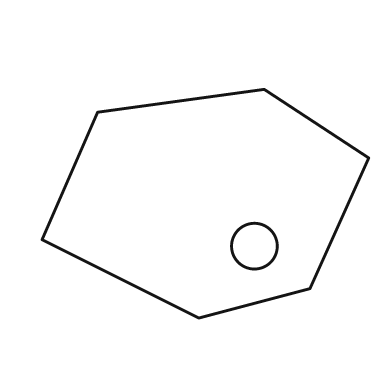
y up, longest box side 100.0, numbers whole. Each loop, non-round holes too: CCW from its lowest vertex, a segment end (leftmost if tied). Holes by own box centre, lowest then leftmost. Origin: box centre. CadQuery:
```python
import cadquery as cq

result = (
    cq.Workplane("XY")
    .moveTo(-2.0, -35.0)
    .lineTo(32.0, -26.0)
    .lineTo(50.0, 14.0)
    .lineTo(18.0, 35.0)
    .lineTo(-33.0, 28.0)
    .lineTo(-50.0, -11.0)
    .close()
    .moveTo(15.0, -13.0)
    .circle(7.0)
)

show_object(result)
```